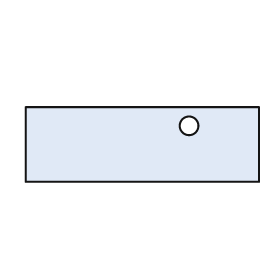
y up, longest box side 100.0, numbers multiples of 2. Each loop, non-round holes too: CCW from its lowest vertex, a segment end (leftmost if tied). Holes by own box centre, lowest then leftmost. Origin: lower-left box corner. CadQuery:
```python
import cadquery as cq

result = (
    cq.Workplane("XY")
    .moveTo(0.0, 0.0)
    .lineTo(100.0, 0.0)
    .lineTo(100.0, 32.0)
    .lineTo(0.0, 32.0)
    .close()
    .moveTo(70.0, 24.0)
    .circle(4.0)
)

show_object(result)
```